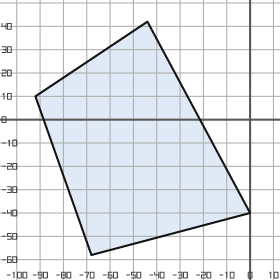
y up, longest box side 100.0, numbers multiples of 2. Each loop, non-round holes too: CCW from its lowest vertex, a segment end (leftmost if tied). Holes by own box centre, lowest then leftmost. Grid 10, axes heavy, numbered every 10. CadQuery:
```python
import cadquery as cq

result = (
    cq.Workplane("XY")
    .moveTo(-68.0, -58.0)
    .lineTo(0.0, -40.0)
    .lineTo(-44.0, 42.0)
    .lineTo(-92.0, 10.0)
    .close()
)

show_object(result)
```